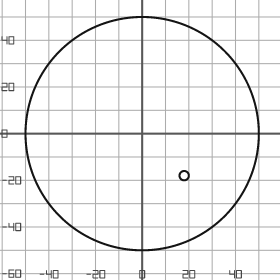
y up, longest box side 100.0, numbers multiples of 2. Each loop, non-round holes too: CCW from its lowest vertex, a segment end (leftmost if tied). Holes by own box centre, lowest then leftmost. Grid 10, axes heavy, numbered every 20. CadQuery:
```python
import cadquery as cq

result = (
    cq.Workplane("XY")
    .moveTo(0.0, 0.0)
    .circle(50.0)
    .moveTo(18.0, -18.0)
    .circle(2.0)
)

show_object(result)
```